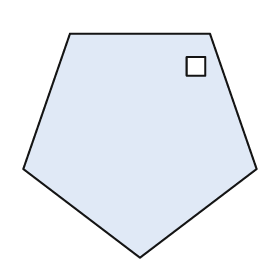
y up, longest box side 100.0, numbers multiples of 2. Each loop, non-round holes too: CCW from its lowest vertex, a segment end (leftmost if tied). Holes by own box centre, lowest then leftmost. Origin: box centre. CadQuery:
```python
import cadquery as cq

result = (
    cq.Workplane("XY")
    .moveTo(0.0, -48.0)
    .lineTo(50.0, -10.0)
    .lineTo(30.0, 48.0)
    .lineTo(-30.0, 48.0)
    .lineTo(-50.0, -10.0)
    .close()
    .moveTo(20.0, 30.0)
    .lineTo(28.0, 30.0)
    .lineTo(28.0, 38.0)
    .lineTo(20.0, 38.0)
    .close()
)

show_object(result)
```